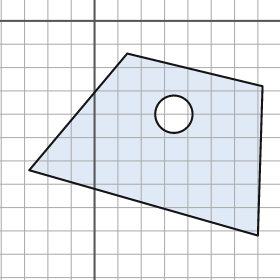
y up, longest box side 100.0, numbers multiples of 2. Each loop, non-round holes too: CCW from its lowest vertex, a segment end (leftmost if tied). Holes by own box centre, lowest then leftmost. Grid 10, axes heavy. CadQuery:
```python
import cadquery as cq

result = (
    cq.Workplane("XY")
    .moveTo(70.0, -92.0)
    .lineTo(72.0, -28.0)
    .lineTo(14.0, -14.0)
    .lineTo(-28.0, -64.0)
    .close()
    .moveTo(34.0, -40.0)
    .circle(8.0)
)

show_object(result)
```